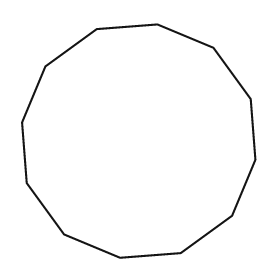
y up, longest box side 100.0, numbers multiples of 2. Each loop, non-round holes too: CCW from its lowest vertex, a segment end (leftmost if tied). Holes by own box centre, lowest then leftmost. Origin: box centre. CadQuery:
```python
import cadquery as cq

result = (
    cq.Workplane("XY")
    .moveTo(-8.0, -50.0)
    .lineTo(18.0, -48.0)
    .lineTo(40.0, -32.0)
    .lineTo(50.0, -8.0)
    .lineTo(48.0, 18.0)
    .lineTo(32.0, 40.0)
    .lineTo(8.0, 50.0)
    .lineTo(-18.0, 48.0)
    .lineTo(-40.0, 32.0)
    .lineTo(-50.0, 8.0)
    .lineTo(-48.0, -18.0)
    .lineTo(-32.0, -40.0)
    .close()
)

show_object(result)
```